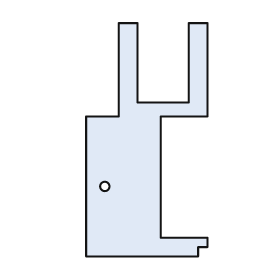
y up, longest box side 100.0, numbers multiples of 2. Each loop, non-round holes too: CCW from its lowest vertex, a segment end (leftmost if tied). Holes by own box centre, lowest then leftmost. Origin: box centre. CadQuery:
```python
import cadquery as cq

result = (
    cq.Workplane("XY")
    .moveTo(-26.0, -50.0)
    .lineTo(22.0, -50.0)
    .lineTo(22.0, -46.0)
    .lineTo(26.0, -46.0)
    .lineTo(26.0, -42.0)
    .lineTo(6.0, -42.0)
    .lineTo(6.0, 10.0)
    .lineTo(26.0, 10.0)
    .lineTo(26.0, 50.0)
    .lineTo(18.0, 50.0)
    .lineTo(18.0, 16.0)
    .lineTo(-4.0, 16.0)
    .lineTo(-4.0, 50.0)
    .lineTo(-12.0, 50.0)
    .lineTo(-12.0, 10.0)
    .lineTo(-26.0, 10.0)
    .close()
    .moveTo(-18.0, -20.0)
    .circle(2.0)
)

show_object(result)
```